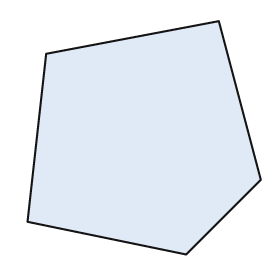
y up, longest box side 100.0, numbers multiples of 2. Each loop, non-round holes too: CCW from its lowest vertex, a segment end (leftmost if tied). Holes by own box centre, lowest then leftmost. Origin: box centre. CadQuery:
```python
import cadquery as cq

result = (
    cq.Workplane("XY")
    .moveTo(18.0, -50.0)
    .lineTo(50.0, -18.0)
    .lineTo(32.0, 50.0)
    .lineTo(-42.0, 36.0)
    .lineTo(-50.0, -36.0)
    .close()
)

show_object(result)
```